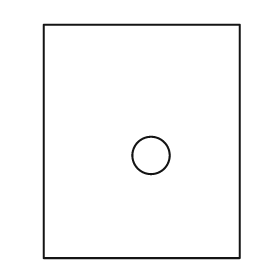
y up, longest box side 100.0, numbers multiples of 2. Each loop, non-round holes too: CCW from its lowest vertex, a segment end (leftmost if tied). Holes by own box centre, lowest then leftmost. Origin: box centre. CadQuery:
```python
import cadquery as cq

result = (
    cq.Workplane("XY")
    .moveTo(-42.0, -50.0)
    .lineTo(42.0, -50.0)
    .lineTo(42.0, 50.0)
    .lineTo(-42.0, 50.0)
    .close()
    .moveTo(4.0, -6.0)
    .circle(8.0)
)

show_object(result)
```